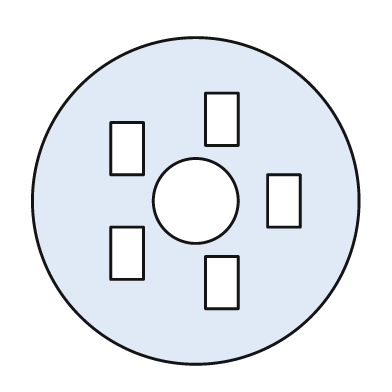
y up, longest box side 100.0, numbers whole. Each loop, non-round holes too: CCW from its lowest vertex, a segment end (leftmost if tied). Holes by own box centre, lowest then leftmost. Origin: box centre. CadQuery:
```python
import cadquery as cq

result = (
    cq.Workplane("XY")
    .moveTo(0.0, 0.0)
    .circle(50.0)
    .moveTo(3.0, -33.0)
    .lineTo(13.0, -33.0)
    .lineTo(13.0, -17.0)
    .lineTo(3.0, -17.0)
    .close()
    .moveTo(-26.0, -24.0)
    .lineTo(-16.0, -24.0)
    .lineTo(-16.0, -8.0)
    .lineTo(-26.0, -8.0)
    .close()
    .moveTo(0.0, 0.0)
    .circle(13.0)
    .moveTo(22.0, -8.0)
    .lineTo(32.0, -8.0)
    .lineTo(32.0, 8.0)
    .lineTo(22.0, 8.0)
    .close()
    .moveTo(-26.0, 8.0)
    .lineTo(-16.0, 8.0)
    .lineTo(-16.0, 24.0)
    .lineTo(-26.0, 24.0)
    .close()
    .moveTo(3.0, 17.0)
    .lineTo(13.0, 17.0)
    .lineTo(13.0, 33.0)
    .lineTo(3.0, 33.0)
    .close()
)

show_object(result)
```